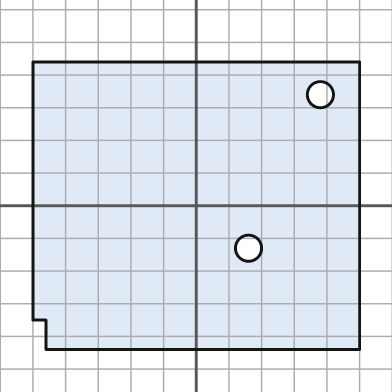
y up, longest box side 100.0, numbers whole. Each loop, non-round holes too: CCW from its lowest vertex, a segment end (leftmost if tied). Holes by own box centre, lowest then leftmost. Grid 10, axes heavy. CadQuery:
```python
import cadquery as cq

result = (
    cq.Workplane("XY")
    .moveTo(-46.0, -44.0)
    .lineTo(50.0, -44.0)
    .lineTo(50.0, 44.0)
    .lineTo(-50.0, 44.0)
    .lineTo(-50.0, -35.0)
    .lineTo(-46.0, -35.0)
    .close()
    .moveTo(16.0, -13.0)
    .circle(4.0)
    .moveTo(38.0, 34.0)
    .circle(4.0)
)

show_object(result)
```